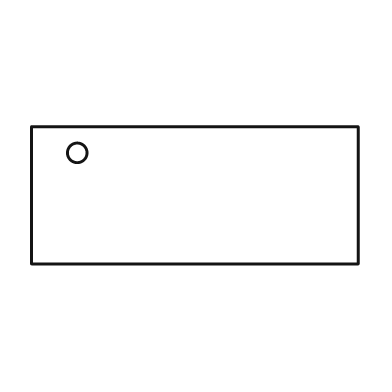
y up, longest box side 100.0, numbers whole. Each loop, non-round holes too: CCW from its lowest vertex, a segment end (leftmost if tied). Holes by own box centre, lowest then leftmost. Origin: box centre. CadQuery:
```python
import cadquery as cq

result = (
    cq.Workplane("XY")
    .moveTo(-50.0, -21.0)
    .lineTo(50.0, -21.0)
    .lineTo(50.0, 21.0)
    .lineTo(-50.0, 21.0)
    .close()
    .moveTo(-36.0, 13.0)
    .circle(3.0)
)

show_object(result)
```